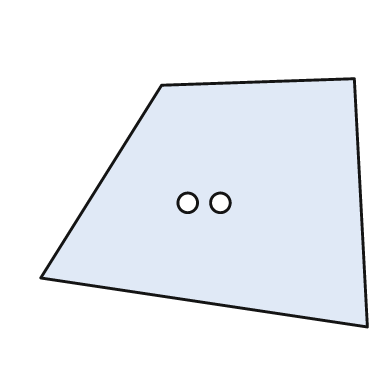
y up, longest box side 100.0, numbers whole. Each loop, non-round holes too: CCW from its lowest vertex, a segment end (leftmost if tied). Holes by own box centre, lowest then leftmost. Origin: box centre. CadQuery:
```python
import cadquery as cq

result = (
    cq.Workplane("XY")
    .moveTo(50.0, -38.0)
    .lineTo(46.0, 38.0)
    .lineTo(-13.0, 36.0)
    .lineTo(-50.0, -23.0)
    .close()
    .moveTo(-5.0, 0.0)
    .circle(3.0)
    .moveTo(5.0, 0.0)
    .circle(3.0)
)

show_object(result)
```